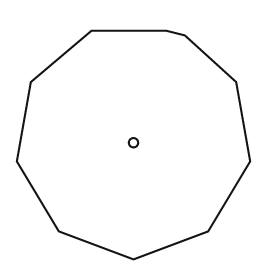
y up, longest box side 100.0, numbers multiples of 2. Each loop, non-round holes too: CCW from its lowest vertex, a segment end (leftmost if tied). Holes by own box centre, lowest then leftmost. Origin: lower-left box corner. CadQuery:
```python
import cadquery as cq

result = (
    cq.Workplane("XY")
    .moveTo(50.0, 0.0)
    .lineTo(82.0, 12.0)
    .lineTo(100.0, 42.0)
    .lineTo(94.0, 76.0)
    .lineTo(72.0, 96.0)
    .lineTo(64.0, 98.0)
    .lineTo(32.0, 98.0)
    .lineTo(6.0, 76.0)
    .lineTo(0.0, 42.0)
    .lineTo(18.0, 12.0)
    .close()
    .moveTo(50.0, 50.0)
    .circle(2.0)
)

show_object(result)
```